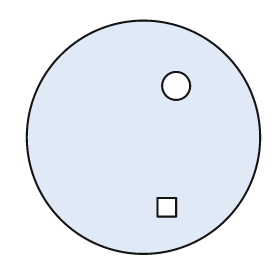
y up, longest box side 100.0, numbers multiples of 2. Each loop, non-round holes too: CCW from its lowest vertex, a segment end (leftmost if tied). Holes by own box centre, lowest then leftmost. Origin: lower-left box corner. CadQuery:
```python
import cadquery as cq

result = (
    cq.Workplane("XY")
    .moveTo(50.0, 50.0)
    .circle(50.0)
    .moveTo(56.0, 16.0)
    .lineTo(64.0, 16.0)
    .lineTo(64.0, 24.0)
    .lineTo(56.0, 24.0)
    .close()
    .moveTo(64.0, 72.0)
    .circle(6.0)
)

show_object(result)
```